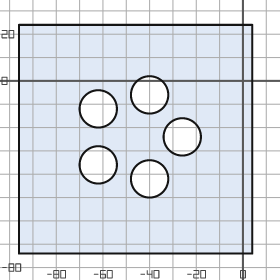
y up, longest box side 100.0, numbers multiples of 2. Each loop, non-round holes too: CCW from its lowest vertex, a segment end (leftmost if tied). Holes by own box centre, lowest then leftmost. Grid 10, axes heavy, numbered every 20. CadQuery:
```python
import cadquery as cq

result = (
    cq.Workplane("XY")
    .moveTo(-96.0, -74.0)
    .lineTo(4.0, -74.0)
    .lineTo(4.0, 24.0)
    .lineTo(-96.0, 24.0)
    .close()
    .moveTo(-40.0, -42.0)
    .circle(8.0)
    .moveTo(-62.0, -36.0)
    .circle(8.0)
    .moveTo(-26.0, -24.0)
    .circle(8.0)
    .moveTo(-62.0, -12.0)
    .circle(8.0)
    .moveTo(-40.0, -6.0)
    .circle(8.0)
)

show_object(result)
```